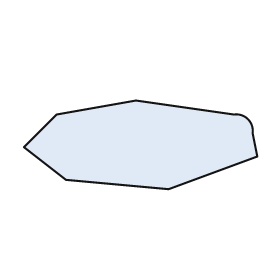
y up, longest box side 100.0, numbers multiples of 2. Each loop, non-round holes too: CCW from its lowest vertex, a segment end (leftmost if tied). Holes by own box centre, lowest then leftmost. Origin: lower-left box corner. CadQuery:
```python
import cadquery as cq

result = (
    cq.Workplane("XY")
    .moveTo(62.0, 0.0)
    .lineTo(100.0, 14.0)
    .lineTo(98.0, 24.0)
    .threePointArc((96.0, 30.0), (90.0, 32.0))
    .lineTo(48.0, 38.0)
    .lineTo(14.0, 32.0)
    .lineTo(0.0, 18.0)
    .lineTo(18.0, 4.0)
    .close()
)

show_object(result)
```